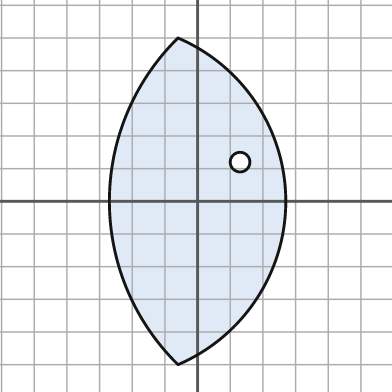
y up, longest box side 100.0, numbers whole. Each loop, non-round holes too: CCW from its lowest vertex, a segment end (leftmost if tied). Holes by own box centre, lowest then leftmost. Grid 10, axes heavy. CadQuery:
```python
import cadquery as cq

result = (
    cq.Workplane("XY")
    .moveTo(-6.0, -50.0)
    .threePointArc((27.0, 0.0), (-6.0, 50.0))
    .threePointArc((-27.0, 0.0), (-6.0, -50.0))
    .close()
    .moveTo(13.0, 12.0)
    .circle(3.0)
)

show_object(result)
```